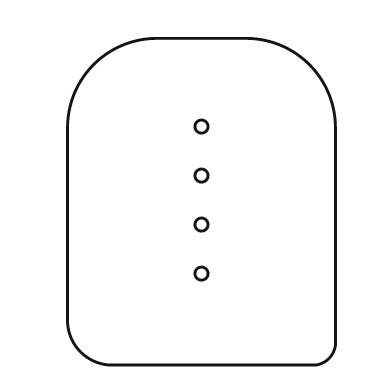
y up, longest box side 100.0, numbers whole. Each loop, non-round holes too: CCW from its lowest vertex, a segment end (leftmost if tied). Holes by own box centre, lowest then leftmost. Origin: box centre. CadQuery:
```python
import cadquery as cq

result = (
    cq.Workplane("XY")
    .moveTo(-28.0, -50.0)
    .lineTo(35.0, -50.0)
    .threePointArc((39.0, -48.0), (41.0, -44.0))
    .lineTo(41.0, 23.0)
    .threePointArc((33.0, 42.0), (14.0, 50.0))
    .lineTo(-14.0, 50.0)
    .threePointArc((-33.0, 42.0), (-41.0, 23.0))
    .lineTo(-41.0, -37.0)
    .threePointArc((-37.0, -46.0), (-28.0, -50.0))
    .close()
    .moveTo(0.0, -22.0)
    .circle(2.0)
    .moveTo(0.0, -7.0)
    .circle(2.0)
    .moveTo(0.0, 8.0)
    .circle(2.0)
    .moveTo(0.0, 23.0)
    .circle(2.0)
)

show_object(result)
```